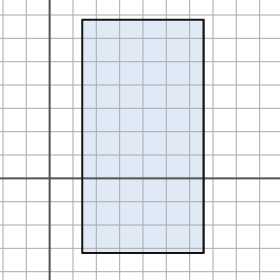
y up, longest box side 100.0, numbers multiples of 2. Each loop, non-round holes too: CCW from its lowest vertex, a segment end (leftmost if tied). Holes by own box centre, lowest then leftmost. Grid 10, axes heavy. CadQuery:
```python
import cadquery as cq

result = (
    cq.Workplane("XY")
    .moveTo(14.0, -32.0)
    .lineTo(66.0, -32.0)
    .lineTo(66.0, 68.0)
    .lineTo(14.0, 68.0)
    .close()
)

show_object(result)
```